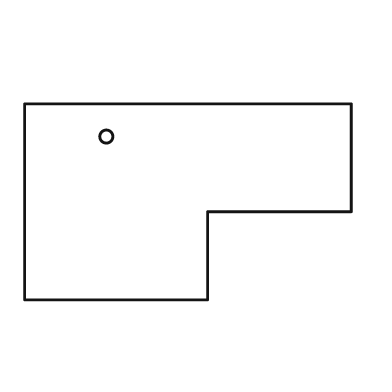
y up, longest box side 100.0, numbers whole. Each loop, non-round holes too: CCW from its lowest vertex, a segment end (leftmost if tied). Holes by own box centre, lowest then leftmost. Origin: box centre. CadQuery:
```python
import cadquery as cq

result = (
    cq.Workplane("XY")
    .moveTo(-50.0, -30.0)
    .lineTo(6.0, -30.0)
    .lineTo(6.0, -3.0)
    .lineTo(50.0, -3.0)
    .lineTo(50.0, 30.0)
    .lineTo(-50.0, 30.0)
    .close()
    .moveTo(-25.0, 20.0)
    .circle(2.0)
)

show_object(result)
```